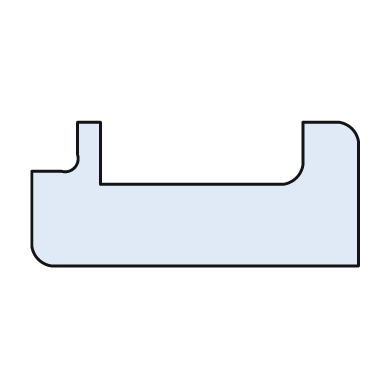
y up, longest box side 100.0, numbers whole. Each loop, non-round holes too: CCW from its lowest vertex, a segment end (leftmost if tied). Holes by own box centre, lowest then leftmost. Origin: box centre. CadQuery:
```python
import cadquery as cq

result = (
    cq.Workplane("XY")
    .moveTo(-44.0, -22.0)
    .lineTo(50.0, -22.0)
    .lineTo(50.0, 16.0)
    .threePointArc((48.0, 20.0), (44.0, 22.0))
    .lineTo(33.0, 22.0)
    .lineTo(33.0, 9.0)
    .threePointArc((31.0, 5.0), (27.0, 3.0))
    .lineTo(-29.0, 3.0)
    .lineTo(-29.0, 22.0)
    .lineTo(-36.0, 22.0)
    .lineTo(-36.0, 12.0)
    .threePointArc((-37.0, 8.0), (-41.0, 7.0))
    .lineTo(-50.0, 7.0)
    .lineTo(-50.0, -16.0)
    .threePointArc((-48.0, -20.0), (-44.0, -22.0))
    .close()
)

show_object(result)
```